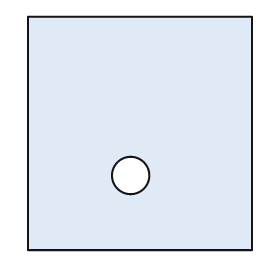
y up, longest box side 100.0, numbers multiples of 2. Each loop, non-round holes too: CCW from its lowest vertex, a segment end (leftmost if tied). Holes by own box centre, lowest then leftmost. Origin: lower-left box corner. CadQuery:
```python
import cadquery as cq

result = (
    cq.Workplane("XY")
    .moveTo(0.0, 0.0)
    .lineTo(96.0, 0.0)
    .lineTo(96.0, 100.0)
    .lineTo(0.0, 100.0)
    .close()
    .moveTo(44.0, 32.0)
    .circle(8.0)
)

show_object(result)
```